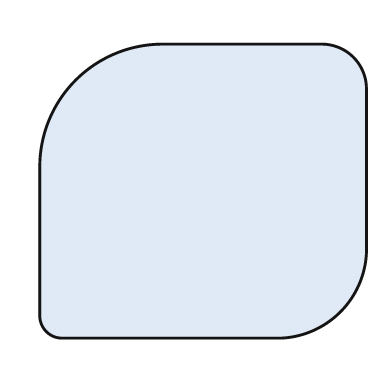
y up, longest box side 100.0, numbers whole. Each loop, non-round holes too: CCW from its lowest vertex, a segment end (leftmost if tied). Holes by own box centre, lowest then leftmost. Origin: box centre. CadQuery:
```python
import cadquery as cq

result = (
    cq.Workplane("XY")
    .moveTo(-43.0, -45.0)
    .lineTo(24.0, -45.0)
    .threePointArc((42.0, -37.0), (50.0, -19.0))
    .lineTo(50.0, 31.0)
    .threePointArc((46.0, 41.0), (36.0, 45.0))
    .lineTo(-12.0, 45.0)
    .threePointArc((-39.0, 34.0), (-50.0, 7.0))
    .lineTo(-50.0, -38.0)
    .threePointArc((-48.0, -43.0), (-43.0, -45.0))
    .close()
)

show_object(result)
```